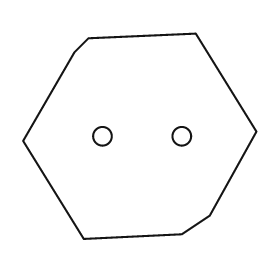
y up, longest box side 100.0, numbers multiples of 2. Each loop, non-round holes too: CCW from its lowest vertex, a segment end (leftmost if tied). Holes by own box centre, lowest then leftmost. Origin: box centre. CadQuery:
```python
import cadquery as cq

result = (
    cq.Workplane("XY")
    .moveTo(-24.0, -44.0)
    .lineTo(18.0, -42.0)
    .lineTo(30.0, -34.0)
    .lineTo(50.0, 2.0)
    .lineTo(24.0, 44.0)
    .lineTo(-22.0, 42.0)
    .lineTo(-28.0, 36.0)
    .lineTo(-50.0, -2.0)
    .close()
    .moveTo(-16.0, 0.0)
    .circle(4.0)
    .moveTo(18.0, 0.0)
    .circle(4.0)
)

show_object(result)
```